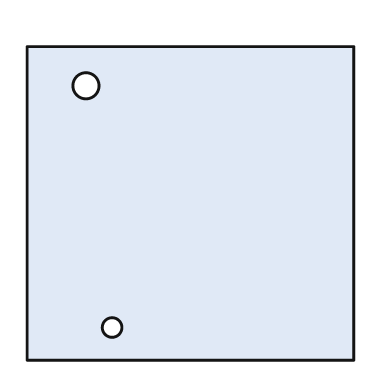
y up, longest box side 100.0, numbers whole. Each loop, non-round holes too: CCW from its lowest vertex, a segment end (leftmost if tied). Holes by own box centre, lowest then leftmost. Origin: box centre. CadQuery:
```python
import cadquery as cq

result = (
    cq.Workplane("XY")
    .moveTo(-50.0, -48.0)
    .lineTo(50.0, -48.0)
    .lineTo(50.0, 48.0)
    .lineTo(-50.0, 48.0)
    .close()
    .moveTo(-24.0, -38.0)
    .circle(3.0)
    .moveTo(-32.0, 36.0)
    .circle(4.0)
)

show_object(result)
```